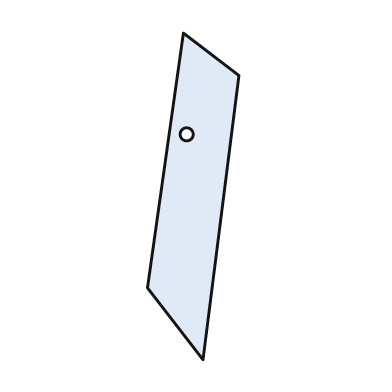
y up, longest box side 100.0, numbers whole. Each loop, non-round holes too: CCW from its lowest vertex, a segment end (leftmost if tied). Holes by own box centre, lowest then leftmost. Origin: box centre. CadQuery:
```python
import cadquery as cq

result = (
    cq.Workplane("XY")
    .moveTo(3.0, -50.0)
    .lineTo(14.0, 37.0)
    .lineTo(-3.0, 50.0)
    .lineTo(-14.0, -28.0)
    .close()
    .moveTo(-2.0, 19.0)
    .circle(2.0)
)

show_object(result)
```